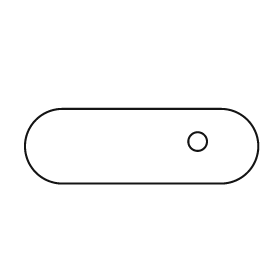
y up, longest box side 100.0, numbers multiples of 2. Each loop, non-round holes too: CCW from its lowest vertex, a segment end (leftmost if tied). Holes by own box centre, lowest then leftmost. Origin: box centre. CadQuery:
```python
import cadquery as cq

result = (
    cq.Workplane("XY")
    .moveTo(-34.0, -16.0)
    .lineTo(34.0, -16.0)
    .threePointArc((50.0, 0.0), (34.0, 16.0))
    .lineTo(-34.0, 16.0)
    .threePointArc((-50.0, 0.0), (-34.0, -16.0))
    .close()
    .moveTo(24.0, 2.0)
    .circle(4.0)
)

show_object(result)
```